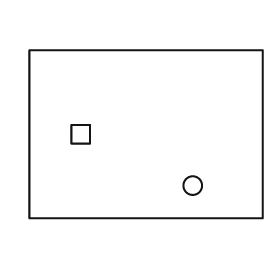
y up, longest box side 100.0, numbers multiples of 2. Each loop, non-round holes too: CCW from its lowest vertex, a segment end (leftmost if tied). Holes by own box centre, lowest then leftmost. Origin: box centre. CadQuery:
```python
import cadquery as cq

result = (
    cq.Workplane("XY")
    .moveTo(-50.0, -36.0)
    .lineTo(50.0, -36.0)
    .lineTo(50.0, 36.0)
    .lineTo(-50.0, 36.0)
    .close()
    .moveTo(20.0, -22.0)
    .circle(4.0)
    .moveTo(-32.0, -4.0)
    .lineTo(-24.0, -4.0)
    .lineTo(-24.0, 4.0)
    .lineTo(-32.0, 4.0)
    .close()
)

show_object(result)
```